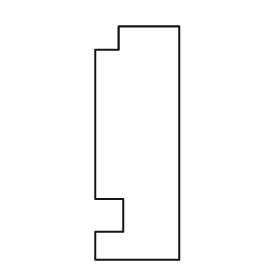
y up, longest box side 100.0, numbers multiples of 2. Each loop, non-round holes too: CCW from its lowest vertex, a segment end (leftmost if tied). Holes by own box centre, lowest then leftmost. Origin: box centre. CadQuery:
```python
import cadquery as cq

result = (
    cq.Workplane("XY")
    .moveTo(-18.0, -50.0)
    .lineTo(18.0, -50.0)
    .lineTo(18.0, 50.0)
    .lineTo(-8.0, 50.0)
    .lineTo(-8.0, 40.0)
    .lineTo(-18.0, 40.0)
    .lineTo(-18.0, -24.0)
    .lineTo(-6.0, -24.0)
    .lineTo(-6.0, -38.0)
    .lineTo(-18.0, -38.0)
    .close()
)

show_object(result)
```